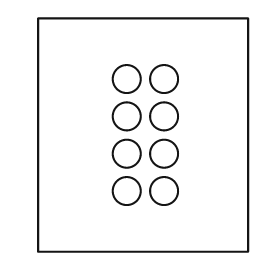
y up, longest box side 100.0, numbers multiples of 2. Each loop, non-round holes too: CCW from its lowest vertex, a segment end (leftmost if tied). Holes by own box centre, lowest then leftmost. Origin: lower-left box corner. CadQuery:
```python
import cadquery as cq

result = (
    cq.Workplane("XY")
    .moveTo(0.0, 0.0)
    .lineTo(90.0, 0.0)
    .lineTo(90.0, 100.0)
    .lineTo(0.0, 100.0)
    .close()
    .moveTo(38.0, 26.0)
    .circle(6.0)
    .moveTo(54.0, 26.0)
    .circle(6.0)
    .moveTo(38.0, 42.0)
    .circle(6.0)
    .moveTo(54.0, 42.0)
    .circle(6.0)
    .moveTo(38.0, 58.0)
    .circle(6.0)
    .moveTo(54.0, 58.0)
    .circle(6.0)
    .moveTo(38.0, 74.0)
    .circle(6.0)
    .moveTo(54.0, 74.0)
    .circle(6.0)
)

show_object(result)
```